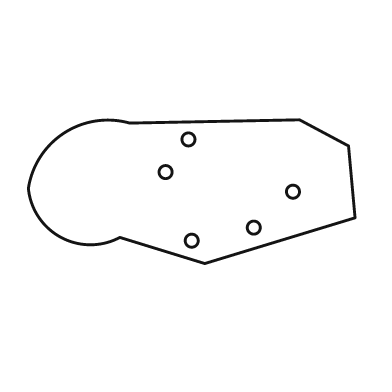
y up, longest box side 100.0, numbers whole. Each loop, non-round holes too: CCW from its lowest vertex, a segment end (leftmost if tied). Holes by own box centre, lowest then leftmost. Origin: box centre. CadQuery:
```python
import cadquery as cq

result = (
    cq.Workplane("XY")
    .moveTo(4.0, -22.0)
    .lineTo(50.0, -8.0)
    .lineTo(48.0, 14.0)
    .lineTo(33.0, 22.0)
    .lineTo(-19.0, 21.0)
    .threePointArc((-39.0, 18.0), (-50.0, 1.0))
    .threePointArc((-40.0, -14.0), (-22.0, -14.0))
    .close()
    .moveTo(0.0, -15.0)
    .circle(2.0)
    .moveTo(19.0, -11.0)
    .circle(2.0)
    .moveTo(31.0, 0.0)
    .circle(2.0)
    .moveTo(-8.0, 6.0)
    .circle(2.0)
    .moveTo(-1.0, 16.0)
    .circle(2.0)
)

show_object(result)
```